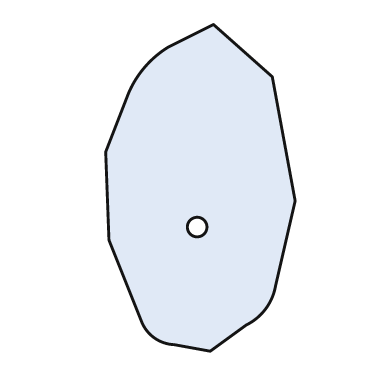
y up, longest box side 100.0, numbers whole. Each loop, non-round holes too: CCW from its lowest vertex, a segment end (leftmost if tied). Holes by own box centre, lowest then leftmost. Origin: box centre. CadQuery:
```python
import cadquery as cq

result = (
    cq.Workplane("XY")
    .moveTo(3.0, -50.0)
    .lineTo(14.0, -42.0)
    .threePointArc((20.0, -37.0), (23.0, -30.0))
    .lineTo(29.0, -4.0)
    .lineTo(22.0, 34.0)
    .lineTo(4.0, 50.0)
    .lineTo(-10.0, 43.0)
    .threePointArc((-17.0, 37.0), (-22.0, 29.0))
    .lineTo(-29.0, 11.0)
    .lineTo(-28.0, -16.0)
    .lineTo(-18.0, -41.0)
    .threePointArc((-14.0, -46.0), (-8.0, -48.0))
    .close()
    .moveTo(-1.0, -12.0)
    .circle(3.0)
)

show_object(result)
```